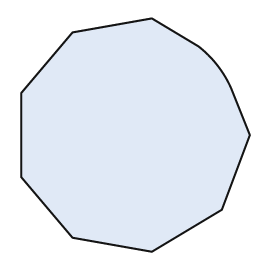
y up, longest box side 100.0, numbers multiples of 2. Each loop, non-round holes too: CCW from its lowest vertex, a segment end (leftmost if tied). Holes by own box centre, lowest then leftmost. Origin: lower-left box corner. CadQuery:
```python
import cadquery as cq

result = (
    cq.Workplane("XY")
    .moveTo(56.0, 0.0)
    .lineTo(86.0, 18.0)
    .lineTo(98.0, 50.0)
    .lineTo(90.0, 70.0)
    .threePointArc((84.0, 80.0), (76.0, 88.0))
    .lineTo(56.0, 100.0)
    .lineTo(22.0, 94.0)
    .lineTo(0.0, 68.0)
    .lineTo(0.0, 32.0)
    .lineTo(22.0, 6.0)
    .close()
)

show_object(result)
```